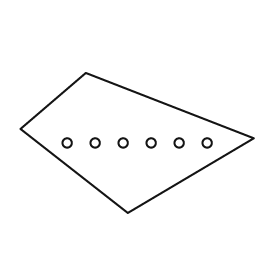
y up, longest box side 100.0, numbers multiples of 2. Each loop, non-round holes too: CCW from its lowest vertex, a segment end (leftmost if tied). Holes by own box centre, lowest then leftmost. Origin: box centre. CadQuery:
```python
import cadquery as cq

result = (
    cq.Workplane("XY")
    .moveTo(-4.0, -30.0)
    .lineTo(50.0, 2.0)
    .lineTo(-22.0, 30.0)
    .lineTo(-50.0, 6.0)
    .close()
    .moveTo(-30.0, 0.0)
    .circle(2.0)
    .moveTo(-18.0, 0.0)
    .circle(2.0)
    .moveTo(-6.0, 0.0)
    .circle(2.0)
    .moveTo(6.0, 0.0)
    .circle(2.0)
    .moveTo(18.0, 0.0)
    .circle(2.0)
    .moveTo(30.0, 0.0)
    .circle(2.0)
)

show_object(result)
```